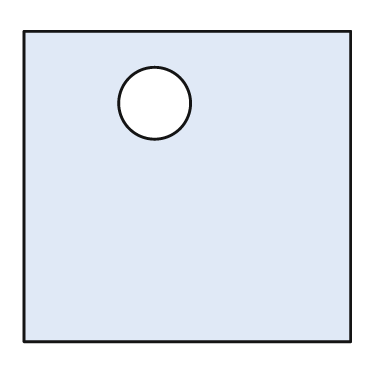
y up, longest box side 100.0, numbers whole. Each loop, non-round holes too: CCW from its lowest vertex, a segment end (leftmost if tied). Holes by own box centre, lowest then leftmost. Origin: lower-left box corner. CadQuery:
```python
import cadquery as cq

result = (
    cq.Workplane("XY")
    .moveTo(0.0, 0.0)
    .lineTo(100.0, 0.0)
    .lineTo(100.0, 95.0)
    .lineTo(0.0, 95.0)
    .close()
    .moveTo(40.0, 73.0)
    .circle(11.0)
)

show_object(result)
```